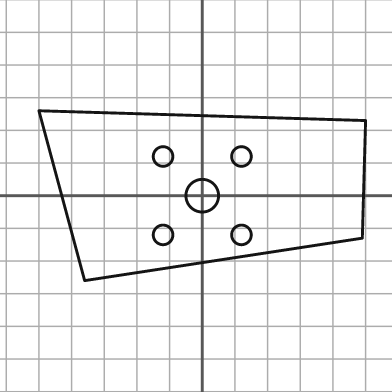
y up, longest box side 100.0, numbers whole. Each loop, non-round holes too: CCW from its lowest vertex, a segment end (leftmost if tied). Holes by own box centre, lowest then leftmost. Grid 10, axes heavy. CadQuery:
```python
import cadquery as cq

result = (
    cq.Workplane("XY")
    .moveTo(-36.0, -26.0)
    .lineTo(49.0, -13.0)
    .lineTo(50.0, 23.0)
    .lineTo(-50.0, 26.0)
    .close()
    .moveTo(-12.0, -12.0)
    .circle(3.0)
    .moveTo(12.0, -12.0)
    .circle(3.0)
    .moveTo(0.0, 0.0)
    .circle(5.0)
    .moveTo(-12.0, 12.0)
    .circle(3.0)
    .moveTo(12.0, 12.0)
    .circle(3.0)
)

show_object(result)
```